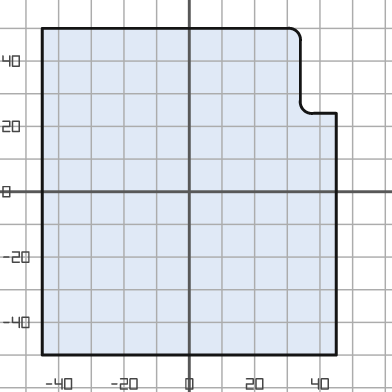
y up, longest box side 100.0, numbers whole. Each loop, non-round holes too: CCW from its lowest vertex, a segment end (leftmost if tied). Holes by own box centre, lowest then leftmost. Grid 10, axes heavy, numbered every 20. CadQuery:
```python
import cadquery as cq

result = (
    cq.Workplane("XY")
    .moveTo(-45.0, -50.0)
    .lineTo(45.0, -50.0)
    .lineTo(45.0, 24.0)
    .lineTo(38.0, 24.0)
    .threePointArc((35.0, 25.0), (34.0, 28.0))
    .lineTo(34.0, 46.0)
    .threePointArc((33.0, 49.0), (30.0, 50.0))
    .lineTo(-45.0, 50.0)
    .close()
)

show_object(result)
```